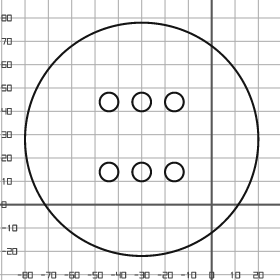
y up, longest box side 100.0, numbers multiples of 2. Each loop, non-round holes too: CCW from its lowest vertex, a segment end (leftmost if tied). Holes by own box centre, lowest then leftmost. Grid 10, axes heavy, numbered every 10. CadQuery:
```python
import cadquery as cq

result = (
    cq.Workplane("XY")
    .moveTo(-30.0, 28.0)
    .circle(50.0)
    .moveTo(-44.0, 14.0)
    .circle(4.0)
    .moveTo(-30.0, 14.0)
    .circle(4.0)
    .moveTo(-16.0, 14.0)
    .circle(4.0)
    .moveTo(-44.0, 44.0)
    .circle(4.0)
    .moveTo(-30.0, 44.0)
    .circle(4.0)
    .moveTo(-16.0, 44.0)
    .circle(4.0)
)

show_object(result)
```